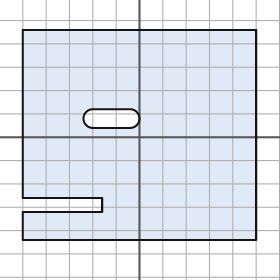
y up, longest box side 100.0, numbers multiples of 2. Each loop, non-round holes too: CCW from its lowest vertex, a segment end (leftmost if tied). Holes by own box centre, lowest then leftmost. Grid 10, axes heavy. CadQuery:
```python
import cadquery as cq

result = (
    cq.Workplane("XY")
    .moveTo(-50.0, -44.0)
    .lineTo(50.0, -44.0)
    .lineTo(50.0, 46.0)
    .lineTo(-50.0, 46.0)
    .lineTo(-50.0, -26.0)
    .lineTo(-16.0, -26.0)
    .lineTo(-16.0, -32.0)
    .lineTo(-50.0, -32.0)
    .close()
    .moveTo(-20.0, 4.0)
    .lineTo(-4.0, 4.0)
    .threePointArc((0.0, 8.0), (-4.0, 12.0))
    .lineTo(-20.0, 12.0)
    .threePointArc((-24.0, 8.0), (-20.0, 4.0))
    .close()
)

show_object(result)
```